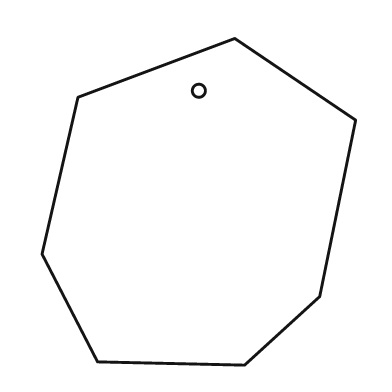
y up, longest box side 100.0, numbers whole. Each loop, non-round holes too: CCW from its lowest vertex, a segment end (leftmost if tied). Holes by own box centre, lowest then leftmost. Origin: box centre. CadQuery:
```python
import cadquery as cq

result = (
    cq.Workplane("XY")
    .moveTo(14.0, -50.0)
    .lineTo(37.0, -29.0)
    .lineTo(48.0, 25.0)
    .lineTo(11.0, 50.0)
    .lineTo(-37.0, 32.0)
    .lineTo(-48.0, -16.0)
    .lineTo(-31.0, -49.0)
    .close()
    .moveTo(0.0, 34.0)
    .circle(2.0)
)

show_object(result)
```